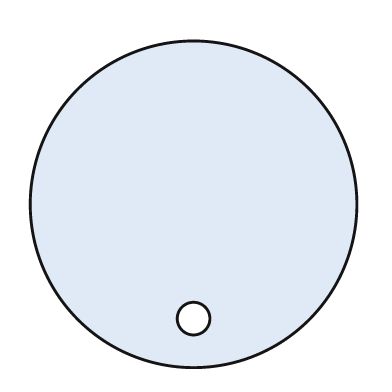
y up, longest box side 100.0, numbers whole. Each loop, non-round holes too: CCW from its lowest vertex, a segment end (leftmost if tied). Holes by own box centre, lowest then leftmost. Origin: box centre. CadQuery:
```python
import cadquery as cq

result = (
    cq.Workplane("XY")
    .moveTo(0.0, 0.0)
    .circle(50.0)
    .moveTo(0.0, -35.0)
    .circle(5.0)
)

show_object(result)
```